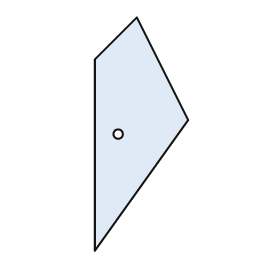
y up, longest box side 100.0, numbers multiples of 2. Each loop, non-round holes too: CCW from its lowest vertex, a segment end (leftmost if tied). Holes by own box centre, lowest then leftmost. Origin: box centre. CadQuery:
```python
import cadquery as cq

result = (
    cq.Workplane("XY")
    .moveTo(-20.0, -50.0)
    .lineTo(20.0, 6.0)
    .lineTo(-2.0, 50.0)
    .lineTo(-20.0, 32.0)
    .close()
    .moveTo(-10.0, 0.0)
    .circle(2.0)
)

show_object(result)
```